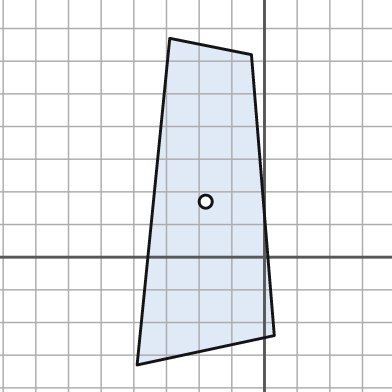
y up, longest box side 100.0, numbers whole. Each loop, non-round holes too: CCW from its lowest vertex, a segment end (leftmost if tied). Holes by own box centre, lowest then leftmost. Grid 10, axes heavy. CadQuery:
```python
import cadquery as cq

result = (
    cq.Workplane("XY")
    .moveTo(-39.0, -33.0)
    .lineTo(3.0, -24.0)
    .lineTo(-4.0, 62.0)
    .lineTo(-29.0, 67.0)
    .close()
    .moveTo(-18.0, 17.0)
    .circle(2.0)
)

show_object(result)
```